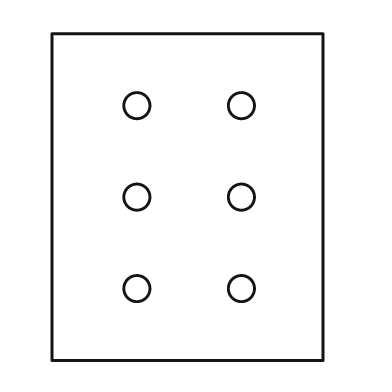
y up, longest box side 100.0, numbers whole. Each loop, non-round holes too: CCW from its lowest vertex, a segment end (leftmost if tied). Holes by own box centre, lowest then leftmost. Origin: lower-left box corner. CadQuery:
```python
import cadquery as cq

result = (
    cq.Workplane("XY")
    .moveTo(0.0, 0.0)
    .lineTo(83.0, 0.0)
    .lineTo(83.0, 100.0)
    .lineTo(0.0, 100.0)
    .close()
    .moveTo(26.0, 22.0)
    .circle(4.0)
    .moveTo(58.0, 22.0)
    .circle(4.0)
    .moveTo(26.0, 50.0)
    .circle(4.0)
    .moveTo(58.0, 50.0)
    .circle(4.0)
    .moveTo(26.0, 78.0)
    .circle(4.0)
    .moveTo(58.0, 78.0)
    .circle(4.0)
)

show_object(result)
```